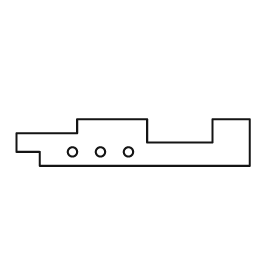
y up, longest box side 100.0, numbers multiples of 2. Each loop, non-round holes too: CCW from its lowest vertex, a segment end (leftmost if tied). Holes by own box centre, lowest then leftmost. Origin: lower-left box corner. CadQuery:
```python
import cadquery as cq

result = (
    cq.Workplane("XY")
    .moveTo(10.0, 0.0)
    .lineTo(100.0, 0.0)
    .lineTo(100.0, 20.0)
    .lineTo(84.0, 20.0)
    .lineTo(84.0, 10.0)
    .lineTo(56.0, 10.0)
    .lineTo(56.0, 20.0)
    .lineTo(26.0, 20.0)
    .lineTo(26.0, 14.0)
    .lineTo(0.0, 14.0)
    .lineTo(0.0, 6.0)
    .lineTo(10.0, 6.0)
    .close()
    .moveTo(24.0, 6.0)
    .circle(2.0)
    .moveTo(36.0, 6.0)
    .circle(2.0)
    .moveTo(48.0, 6.0)
    .circle(2.0)
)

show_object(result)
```